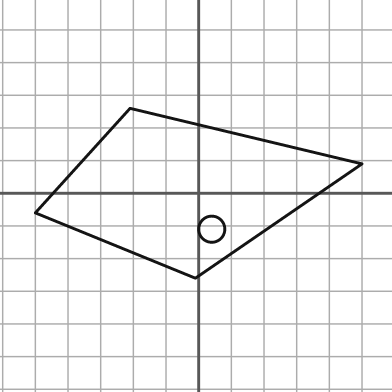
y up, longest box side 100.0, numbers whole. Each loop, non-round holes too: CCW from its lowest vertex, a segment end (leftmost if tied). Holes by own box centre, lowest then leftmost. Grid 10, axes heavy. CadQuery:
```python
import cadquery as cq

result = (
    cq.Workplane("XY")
    .moveTo(-1.0, -26.0)
    .lineTo(50.0, 9.0)
    .lineTo(-21.0, 26.0)
    .lineTo(-50.0, -6.0)
    .close()
    .moveTo(4.0, -11.0)
    .circle(4.0)
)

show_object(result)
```